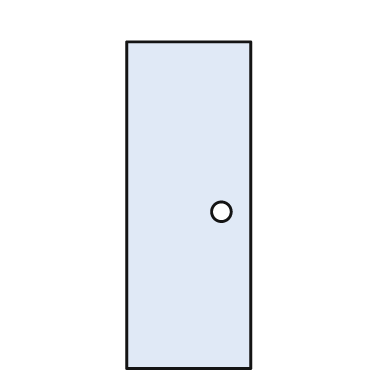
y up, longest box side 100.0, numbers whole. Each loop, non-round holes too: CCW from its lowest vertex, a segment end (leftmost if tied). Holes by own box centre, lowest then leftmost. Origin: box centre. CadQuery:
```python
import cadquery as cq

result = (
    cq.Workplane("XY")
    .moveTo(-19.0, -50.0)
    .lineTo(19.0, -50.0)
    .lineTo(19.0, 50.0)
    .lineTo(-19.0, 50.0)
    .close()
    .moveTo(10.0, -2.0)
    .circle(3.0)
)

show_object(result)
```